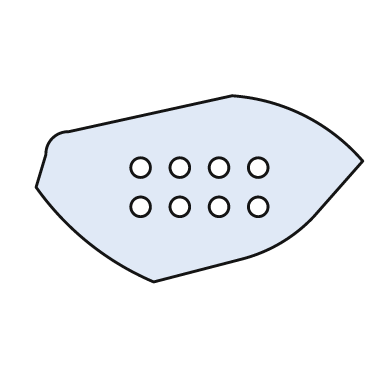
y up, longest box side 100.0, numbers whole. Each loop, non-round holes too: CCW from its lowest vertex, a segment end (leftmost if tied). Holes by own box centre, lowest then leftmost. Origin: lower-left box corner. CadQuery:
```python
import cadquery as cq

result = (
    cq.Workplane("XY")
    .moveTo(36.0, 0.0)
    .lineTo(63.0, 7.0)
    .threePointArc((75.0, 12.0), (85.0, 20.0))
    .lineTo(100.0, 37.0)
    .threePointArc((82.0, 51.0), (60.0, 57.0))
    .lineTo(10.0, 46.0)
    .threePointArc((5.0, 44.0), (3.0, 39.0))
    .lineTo(0.0, 29.0)
    .threePointArc((16.0, 12.0), (36.0, 0.0))
    .close()
    .moveTo(32.0, 23.0)
    .circle(3.0)
    .moveTo(44.0, 23.0)
    .circle(3.0)
    .moveTo(56.0, 23.0)
    .circle(3.0)
    .moveTo(68.0, 23.0)
    .circle(3.0)
    .moveTo(32.0, 35.0)
    .circle(3.0)
    .moveTo(44.0, 35.0)
    .circle(3.0)
    .moveTo(56.0, 35.0)
    .circle(3.0)
    .moveTo(68.0, 35.0)
    .circle(3.0)
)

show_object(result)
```